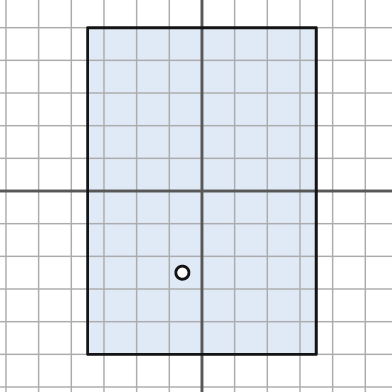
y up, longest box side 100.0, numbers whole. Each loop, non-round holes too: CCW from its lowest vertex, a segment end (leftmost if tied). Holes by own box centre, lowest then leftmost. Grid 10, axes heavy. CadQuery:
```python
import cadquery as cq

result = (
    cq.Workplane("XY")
    .moveTo(-35.0, -50.0)
    .lineTo(35.0, -50.0)
    .lineTo(35.0, 50.0)
    .lineTo(-35.0, 50.0)
    .close()
    .moveTo(-6.0, -25.0)
    .circle(2.0)
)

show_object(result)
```